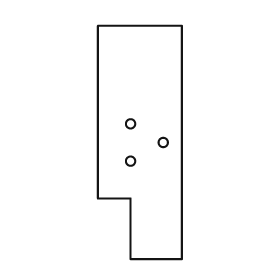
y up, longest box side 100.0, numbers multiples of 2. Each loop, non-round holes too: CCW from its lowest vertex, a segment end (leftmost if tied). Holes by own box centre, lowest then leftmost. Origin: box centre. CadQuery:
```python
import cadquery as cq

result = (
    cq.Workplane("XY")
    .moveTo(-4.0, -50.0)
    .lineTo(18.0, -50.0)
    .lineTo(18.0, 50.0)
    .lineTo(-18.0, 50.0)
    .lineTo(-18.0, -24.0)
    .lineTo(-4.0, -24.0)
    .close()
    .moveTo(-4.0, -8.0)
    .circle(2.0)
    .moveTo(10.0, 0.0)
    .circle(2.0)
    .moveTo(-4.0, 8.0)
    .circle(2.0)
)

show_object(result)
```